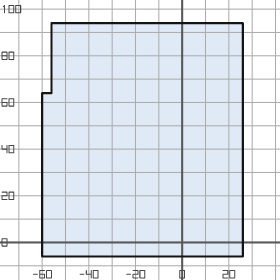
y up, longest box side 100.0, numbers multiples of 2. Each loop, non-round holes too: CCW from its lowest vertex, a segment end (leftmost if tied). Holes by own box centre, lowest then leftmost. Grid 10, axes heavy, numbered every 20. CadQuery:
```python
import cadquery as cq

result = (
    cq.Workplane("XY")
    .moveTo(-60.0, -6.0)
    .lineTo(26.0, -6.0)
    .lineTo(26.0, 94.0)
    .lineTo(-56.0, 94.0)
    .lineTo(-56.0, 64.0)
    .lineTo(-60.0, 64.0)
    .close()
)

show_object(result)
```